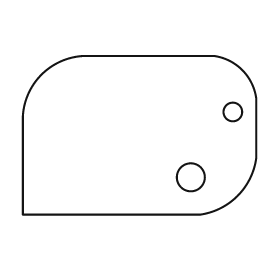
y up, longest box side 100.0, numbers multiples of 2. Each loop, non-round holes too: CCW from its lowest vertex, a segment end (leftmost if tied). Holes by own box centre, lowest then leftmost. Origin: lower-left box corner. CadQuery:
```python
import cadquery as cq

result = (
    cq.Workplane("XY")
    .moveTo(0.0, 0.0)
    .lineTo(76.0, 0.0)
    .threePointArc((92.0, 8.0), (100.0, 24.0))
    .lineTo(100.0, 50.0)
    .threePointArc((94.0, 62.0), (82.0, 68.0))
    .lineTo(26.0, 68.0)
    .threePointArc((8.0, 60.0), (0.0, 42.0))
    .close()
    .moveTo(72.0, 16.0)
    .circle(6.0)
    .moveTo(90.0, 44.0)
    .circle(4.0)
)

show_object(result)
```